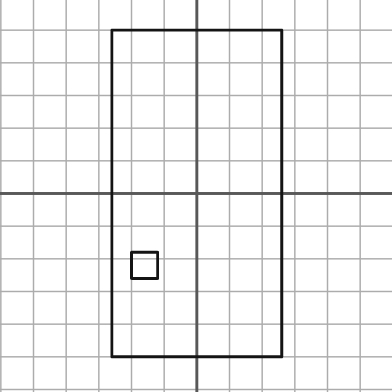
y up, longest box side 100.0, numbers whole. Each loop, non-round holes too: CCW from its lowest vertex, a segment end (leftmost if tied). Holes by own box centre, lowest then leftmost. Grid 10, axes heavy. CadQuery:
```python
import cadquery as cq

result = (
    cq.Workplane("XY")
    .moveTo(-26.0, -50.0)
    .lineTo(26.0, -50.0)
    .lineTo(26.0, 50.0)
    .lineTo(-26.0, 50.0)
    .close()
    .moveTo(-20.0, -26.0)
    .lineTo(-12.0, -26.0)
    .lineTo(-12.0, -18.0)
    .lineTo(-20.0, -18.0)
    .close()
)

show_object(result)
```